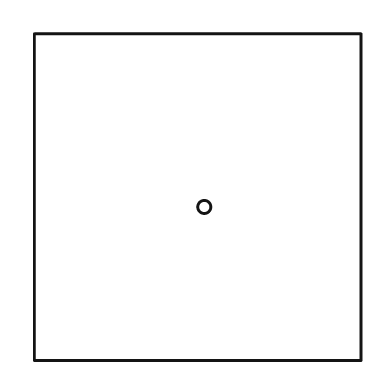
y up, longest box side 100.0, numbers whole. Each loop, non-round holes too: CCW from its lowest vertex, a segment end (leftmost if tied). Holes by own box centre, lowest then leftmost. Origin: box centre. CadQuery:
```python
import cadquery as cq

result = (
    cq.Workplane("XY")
    .moveTo(-50.0, -50.0)
    .lineTo(50.0, -50.0)
    .lineTo(50.0, 50.0)
    .lineTo(-50.0, 50.0)
    .close()
    .moveTo(2.0, -3.0)
    .circle(2.0)
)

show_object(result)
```